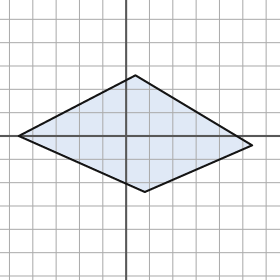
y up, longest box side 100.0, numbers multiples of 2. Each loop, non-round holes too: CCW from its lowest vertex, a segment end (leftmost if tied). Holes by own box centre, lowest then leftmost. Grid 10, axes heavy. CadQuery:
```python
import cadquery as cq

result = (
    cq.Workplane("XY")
    .moveTo(8.0, -24.0)
    .lineTo(54.0, -4.0)
    .lineTo(4.0, 26.0)
    .lineTo(-46.0, 0.0)
    .close()
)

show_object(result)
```